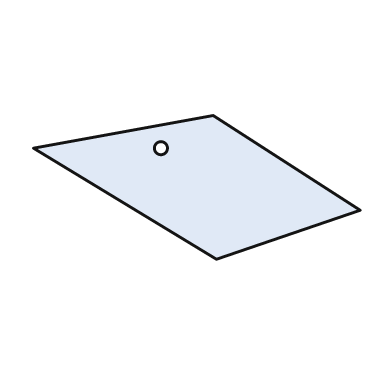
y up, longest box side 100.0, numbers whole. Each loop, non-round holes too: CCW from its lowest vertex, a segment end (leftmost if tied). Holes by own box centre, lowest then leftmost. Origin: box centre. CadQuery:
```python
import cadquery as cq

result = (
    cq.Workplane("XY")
    .moveTo(6.0, -22.0)
    .lineTo(50.0, -7.0)
    .lineTo(5.0, 22.0)
    .lineTo(-50.0, 12.0)
    .close()
    .moveTo(-11.0, 12.0)
    .circle(2.0)
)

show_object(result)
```